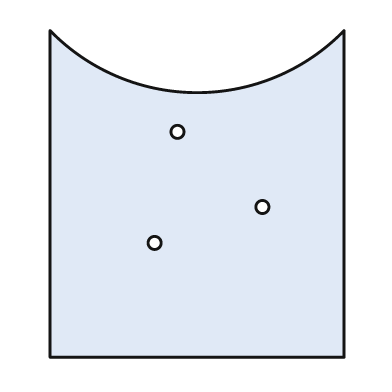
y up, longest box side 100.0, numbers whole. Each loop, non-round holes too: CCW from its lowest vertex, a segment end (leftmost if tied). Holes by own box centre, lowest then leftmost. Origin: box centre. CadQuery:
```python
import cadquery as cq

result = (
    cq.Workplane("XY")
    .moveTo(-45.0, -50.0)
    .lineTo(45.0, -50.0)
    .lineTo(45.0, 50.0)
    .threePointArc((0.0, 31.0), (-45.0, 50.0))
    .close()
    .moveTo(-13.0, -15.0)
    .circle(2.0)
    .moveTo(20.0, -4.0)
    .circle(2.0)
    .moveTo(-6.0, 19.0)
    .circle(2.0)
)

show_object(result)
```